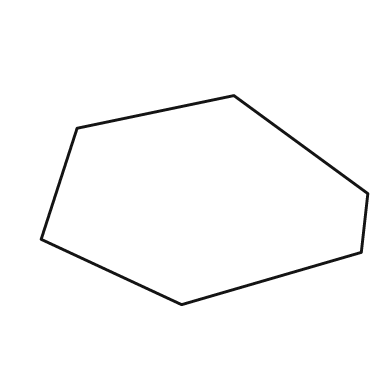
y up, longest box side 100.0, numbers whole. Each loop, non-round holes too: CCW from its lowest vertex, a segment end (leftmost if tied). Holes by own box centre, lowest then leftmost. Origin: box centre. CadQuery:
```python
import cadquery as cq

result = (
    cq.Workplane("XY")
    .moveTo(-7.0, -32.0)
    .lineTo(48.0, -16.0)
    .lineTo(50.0, 2.0)
    .lineTo(9.0, 32.0)
    .lineTo(-39.0, 22.0)
    .lineTo(-50.0, -12.0)
    .close()
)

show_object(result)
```